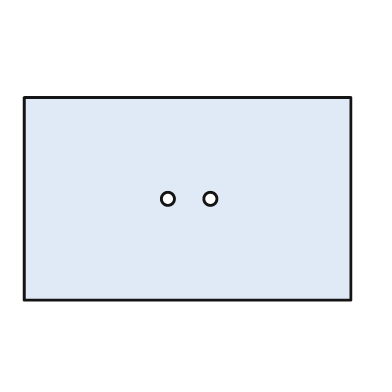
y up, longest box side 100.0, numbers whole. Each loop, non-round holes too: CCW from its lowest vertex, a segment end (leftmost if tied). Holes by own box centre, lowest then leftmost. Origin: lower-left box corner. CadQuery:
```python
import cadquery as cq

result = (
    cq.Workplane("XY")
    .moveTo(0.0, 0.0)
    .lineTo(100.0, 0.0)
    .lineTo(100.0, 62.0)
    .lineTo(0.0, 62.0)
    .close()
    .moveTo(44.0, 31.0)
    .circle(2.0)
    .moveTo(57.0, 31.0)
    .circle(2.0)
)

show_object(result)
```